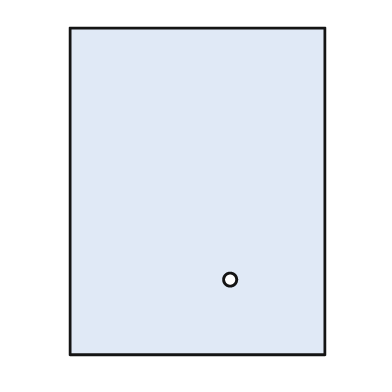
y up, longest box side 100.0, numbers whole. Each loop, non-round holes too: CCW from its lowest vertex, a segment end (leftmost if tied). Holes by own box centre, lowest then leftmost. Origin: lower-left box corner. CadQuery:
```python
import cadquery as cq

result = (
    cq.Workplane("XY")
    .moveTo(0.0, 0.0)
    .lineTo(78.0, 0.0)
    .lineTo(78.0, 100.0)
    .lineTo(0.0, 100.0)
    .close()
    .moveTo(49.0, 23.0)
    .circle(2.0)
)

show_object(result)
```